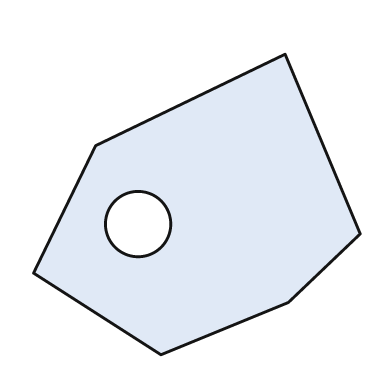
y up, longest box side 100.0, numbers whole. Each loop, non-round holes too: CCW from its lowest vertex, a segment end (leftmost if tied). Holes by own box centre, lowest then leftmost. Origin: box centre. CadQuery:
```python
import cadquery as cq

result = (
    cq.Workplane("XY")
    .moveTo(-11.0, -46.0)
    .lineTo(28.0, -30.0)
    .lineTo(50.0, -9.0)
    .lineTo(27.0, 46.0)
    .lineTo(-31.0, 18.0)
    .lineTo(-50.0, -21.0)
    .close()
    .moveTo(-18.0, -6.0)
    .circle(10.0)
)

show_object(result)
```